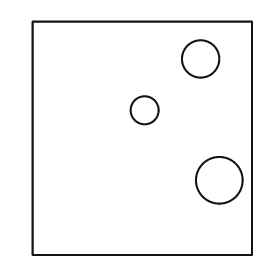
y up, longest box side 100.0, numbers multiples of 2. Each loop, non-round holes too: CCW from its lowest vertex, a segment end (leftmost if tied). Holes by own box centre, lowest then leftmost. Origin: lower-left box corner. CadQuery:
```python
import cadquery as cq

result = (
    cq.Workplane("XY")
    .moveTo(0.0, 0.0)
    .lineTo(94.0, 0.0)
    .lineTo(94.0, 100.0)
    .lineTo(0.0, 100.0)
    .close()
    .moveTo(80.0, 32.0)
    .circle(10.0)
    .moveTo(48.0, 62.0)
    .circle(6.0)
    .moveTo(72.0, 84.0)
    .circle(8.0)
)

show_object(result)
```